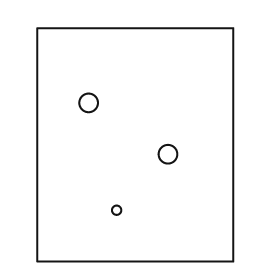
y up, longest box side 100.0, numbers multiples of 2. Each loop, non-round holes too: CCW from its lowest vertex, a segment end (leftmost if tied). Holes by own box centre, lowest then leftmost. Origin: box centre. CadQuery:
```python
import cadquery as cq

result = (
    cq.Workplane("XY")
    .moveTo(-42.0, -50.0)
    .lineTo(42.0, -50.0)
    .lineTo(42.0, 50.0)
    .lineTo(-42.0, 50.0)
    .close()
    .moveTo(-8.0, -28.0)
    .circle(2.0)
    .moveTo(14.0, -4.0)
    .circle(4.0)
    .moveTo(-20.0, 18.0)
    .circle(4.0)
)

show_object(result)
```